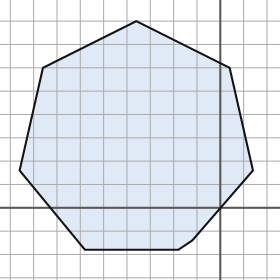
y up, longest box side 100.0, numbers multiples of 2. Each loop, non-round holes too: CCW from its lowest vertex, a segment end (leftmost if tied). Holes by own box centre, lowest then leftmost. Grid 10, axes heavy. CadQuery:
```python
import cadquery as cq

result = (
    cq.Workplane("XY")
    .moveTo(-58.0, -18.0)
    .lineTo(-18.0, -18.0)
    .lineTo(-12.0, -14.0)
    .lineTo(14.0, 16.0)
    .lineTo(4.0, 60.0)
    .lineTo(-36.0, 80.0)
    .lineTo(-76.0, 60.0)
    .lineTo(-86.0, 16.0)
    .close()
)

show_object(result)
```